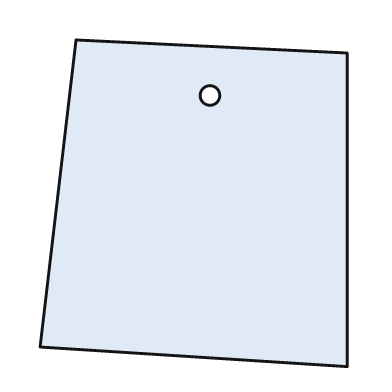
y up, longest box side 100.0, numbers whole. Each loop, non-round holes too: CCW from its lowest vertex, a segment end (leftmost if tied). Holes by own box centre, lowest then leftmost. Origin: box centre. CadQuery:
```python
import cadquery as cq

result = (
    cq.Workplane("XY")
    .moveTo(47.0, -50.0)
    .lineTo(47.0, 46.0)
    .lineTo(-36.0, 50.0)
    .lineTo(-47.0, -44.0)
    .close()
    .moveTo(5.0, 33.0)
    .circle(3.0)
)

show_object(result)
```